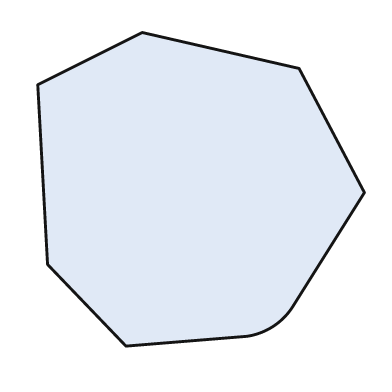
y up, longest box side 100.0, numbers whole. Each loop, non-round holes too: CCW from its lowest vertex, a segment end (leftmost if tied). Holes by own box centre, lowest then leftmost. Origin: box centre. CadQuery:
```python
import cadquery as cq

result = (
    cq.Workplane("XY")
    .moveTo(-23.0, -48.0)
    .lineTo(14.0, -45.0)
    .threePointArc((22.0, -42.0), (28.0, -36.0))
    .lineTo(50.0, -1.0)
    .lineTo(30.0, 37.0)
    .lineTo(-18.0, 48.0)
    .lineTo(-50.0, 32.0)
    .lineTo(-47.0, -23.0)
    .close()
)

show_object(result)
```